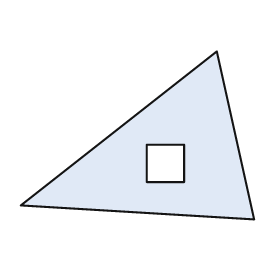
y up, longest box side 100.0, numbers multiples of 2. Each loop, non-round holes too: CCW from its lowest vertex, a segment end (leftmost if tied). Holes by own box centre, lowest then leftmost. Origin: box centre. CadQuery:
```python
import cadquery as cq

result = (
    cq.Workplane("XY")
    .moveTo(50.0, -36.0)
    .lineTo(34.0, 36.0)
    .lineTo(-50.0, -30.0)
    .close()
    .moveTo(4.0, -20.0)
    .lineTo(20.0, -20.0)
    .lineTo(20.0, -4.0)
    .lineTo(4.0, -4.0)
    .close()
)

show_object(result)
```